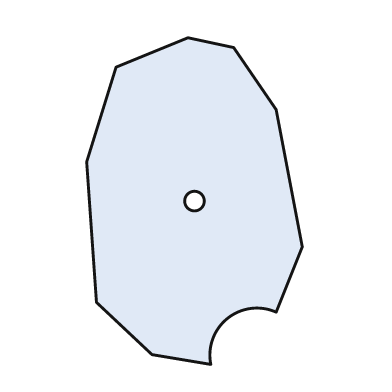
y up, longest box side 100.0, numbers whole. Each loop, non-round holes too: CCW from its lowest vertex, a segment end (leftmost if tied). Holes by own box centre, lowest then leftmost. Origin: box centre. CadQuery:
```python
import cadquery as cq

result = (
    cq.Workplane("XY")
    .moveTo(5.0, -50.0)
    .threePointArc((10.0, -36.0), (25.0, -34.0))
    .lineTo(33.0, -14.0)
    .lineTo(25.0, 28.0)
    .lineTo(12.0, 47.0)
    .lineTo(-2.0, 50.0)
    .lineTo(-24.0, 41.0)
    .lineTo(-33.0, 12.0)
    .lineTo(-30.0, -31.0)
    .lineTo(-13.0, -47.0)
    .close()
    .moveTo(0.0, 0.0)
    .circle(3.0)
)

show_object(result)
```